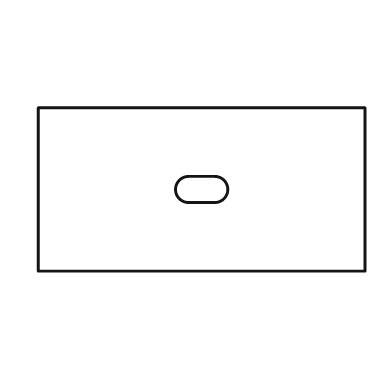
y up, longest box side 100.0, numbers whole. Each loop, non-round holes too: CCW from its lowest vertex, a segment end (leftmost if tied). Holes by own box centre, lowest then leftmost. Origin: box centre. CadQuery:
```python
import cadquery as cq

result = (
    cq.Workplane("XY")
    .moveTo(-50.0, -25.0)
    .lineTo(50.0, -25.0)
    .lineTo(50.0, 25.0)
    .lineTo(-50.0, 25.0)
    .close()
    .moveTo(-4.0, -4.0)
    .lineTo(4.0, -4.0)
    .threePointArc((8.0, 0.0), (4.0, 4.0))
    .lineTo(-4.0, 4.0)
    .threePointArc((-8.0, 0.0), (-4.0, -4.0))
    .close()
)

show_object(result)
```